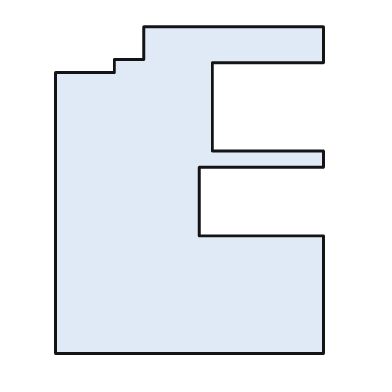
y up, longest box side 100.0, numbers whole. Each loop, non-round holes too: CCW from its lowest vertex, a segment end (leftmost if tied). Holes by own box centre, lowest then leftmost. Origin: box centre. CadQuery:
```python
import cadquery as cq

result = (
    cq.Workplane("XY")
    .moveTo(-41.0, -50.0)
    .lineTo(41.0, -50.0)
    .lineTo(41.0, -14.0)
    .lineTo(3.0, -14.0)
    .lineTo(3.0, 7.0)
    .lineTo(41.0, 7.0)
    .lineTo(41.0, 12.0)
    .lineTo(7.0, 12.0)
    .lineTo(7.0, 39.0)
    .lineTo(41.0, 39.0)
    .lineTo(41.0, 50.0)
    .lineTo(-14.0, 50.0)
    .lineTo(-14.0, 40.0)
    .lineTo(-23.0, 40.0)
    .lineTo(-23.0, 36.0)
    .lineTo(-41.0, 36.0)
    .close()
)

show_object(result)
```